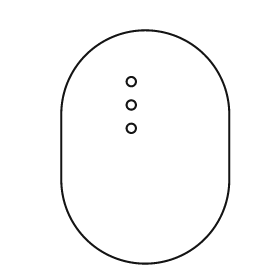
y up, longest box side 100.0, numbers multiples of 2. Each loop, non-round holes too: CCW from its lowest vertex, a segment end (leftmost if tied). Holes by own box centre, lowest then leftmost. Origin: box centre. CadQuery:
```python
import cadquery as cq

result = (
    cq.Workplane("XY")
    .moveTo(-36.0, -14.0)
    .threePointArc((0.0, -50.0), (36.0, -14.0))
    .lineTo(36.0, 14.0)
    .threePointArc((0.0, 50.0), (-36.0, 14.0))
    .close()
    .moveTo(-6.0, 8.0)
    .circle(2.0)
    .moveTo(-6.0, 18.0)
    .circle(2.0)
    .moveTo(-6.0, 28.0)
    .circle(2.0)
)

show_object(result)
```